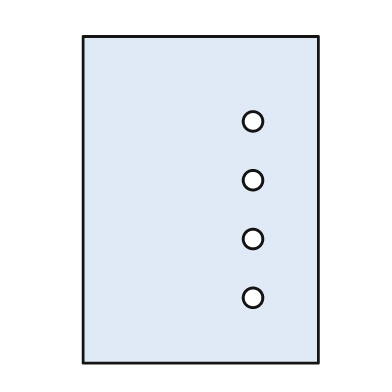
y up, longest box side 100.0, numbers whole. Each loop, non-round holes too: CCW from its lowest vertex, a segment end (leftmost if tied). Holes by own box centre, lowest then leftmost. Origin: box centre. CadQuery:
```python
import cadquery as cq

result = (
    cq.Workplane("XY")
    .moveTo(-36.0, -50.0)
    .lineTo(36.0, -50.0)
    .lineTo(36.0, 50.0)
    .lineTo(-36.0, 50.0)
    .close()
    .moveTo(16.0, -30.0)
    .circle(3.0)
    .moveTo(16.0, -12.0)
    .circle(3.0)
    .moveTo(16.0, 6.0)
    .circle(3.0)
    .moveTo(16.0, 24.0)
    .circle(3.0)
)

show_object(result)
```